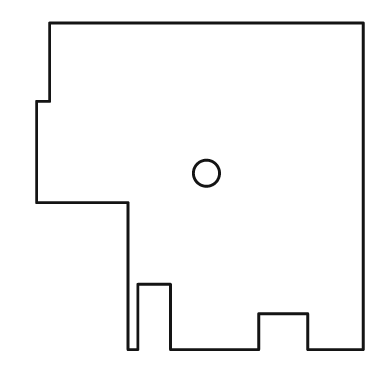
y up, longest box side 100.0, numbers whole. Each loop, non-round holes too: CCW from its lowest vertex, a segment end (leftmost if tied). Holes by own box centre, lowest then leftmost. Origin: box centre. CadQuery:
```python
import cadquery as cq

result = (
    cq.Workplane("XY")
    .moveTo(-22.0, -50.0)
    .lineTo(-19.0, -50.0)
    .lineTo(-19.0, -30.0)
    .lineTo(-9.0, -30.0)
    .lineTo(-9.0, -50.0)
    .lineTo(18.0, -50.0)
    .lineTo(18.0, -39.0)
    .lineTo(33.0, -39.0)
    .lineTo(33.0, -50.0)
    .lineTo(50.0, -50.0)
    .lineTo(50.0, 50.0)
    .lineTo(-46.0, 50.0)
    .lineTo(-46.0, 26.0)
    .lineTo(-50.0, 26.0)
    .lineTo(-50.0, -5.0)
    .lineTo(-22.0, -5.0)
    .close()
    .moveTo(2.0, 4.0)
    .circle(4.0)
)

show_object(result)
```